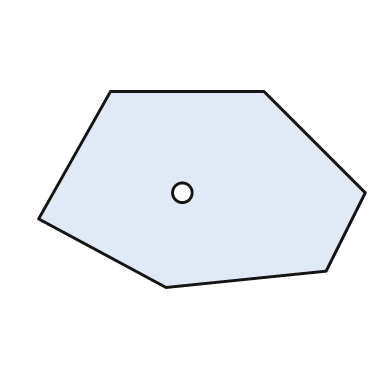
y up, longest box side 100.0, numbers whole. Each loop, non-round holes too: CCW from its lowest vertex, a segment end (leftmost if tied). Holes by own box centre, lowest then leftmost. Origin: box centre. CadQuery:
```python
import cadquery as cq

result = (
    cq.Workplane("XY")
    .moveTo(-11.0, -30.0)
    .lineTo(38.0, -25.0)
    .lineTo(50.0, -1.0)
    .lineTo(19.0, 30.0)
    .lineTo(-28.0, 30.0)
    .lineTo(-50.0, -9.0)
    .close()
    .moveTo(-6.0, -1.0)
    .circle(3.0)
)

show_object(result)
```